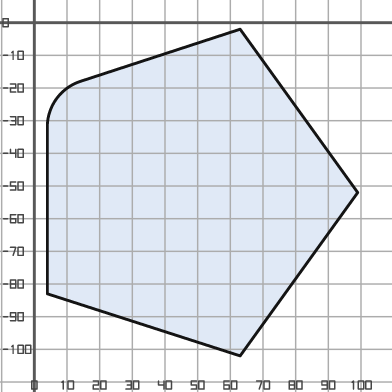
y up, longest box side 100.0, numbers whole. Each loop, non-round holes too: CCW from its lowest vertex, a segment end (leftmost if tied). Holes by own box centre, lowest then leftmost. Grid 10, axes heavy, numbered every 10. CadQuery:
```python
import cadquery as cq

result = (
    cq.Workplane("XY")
    .moveTo(63.0, -102.0)
    .lineTo(99.0, -52.0)
    .lineTo(63.0, -2.0)
    .lineTo(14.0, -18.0)
    .threePointArc((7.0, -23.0), (4.0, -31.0))
    .lineTo(4.0, -83.0)
    .close()
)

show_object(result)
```